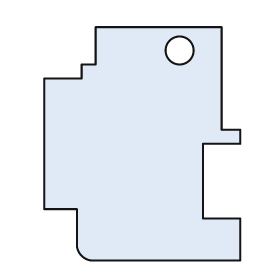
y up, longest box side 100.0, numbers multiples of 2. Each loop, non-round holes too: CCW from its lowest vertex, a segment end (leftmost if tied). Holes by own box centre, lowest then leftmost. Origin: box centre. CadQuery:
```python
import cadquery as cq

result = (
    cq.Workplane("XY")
    .moveTo(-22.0, -50.0)
    .lineTo(42.0, -50.0)
    .lineTo(42.0, -32.0)
    .lineTo(26.0, -32.0)
    .lineTo(26.0, 0.0)
    .lineTo(42.0, 0.0)
    .lineTo(42.0, 6.0)
    .lineTo(34.0, 6.0)
    .lineTo(34.0, 50.0)
    .lineTo(-20.0, 50.0)
    .lineTo(-20.0, 34.0)
    .lineTo(-26.0, 34.0)
    .lineTo(-26.0, 28.0)
    .lineTo(-42.0, 28.0)
    .lineTo(-42.0, -28.0)
    .lineTo(-28.0, -28.0)
    .lineTo(-28.0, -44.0)
    .threePointArc((-26.0, -48.0), (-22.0, -50.0))
    .close()
    .moveTo(16.0, 40.0)
    .circle(6.0)
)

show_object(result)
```